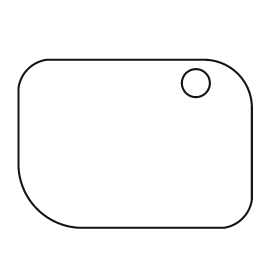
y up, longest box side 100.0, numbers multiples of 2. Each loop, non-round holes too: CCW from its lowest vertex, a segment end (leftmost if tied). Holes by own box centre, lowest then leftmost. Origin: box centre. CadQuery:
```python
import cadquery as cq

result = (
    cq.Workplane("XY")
    .moveTo(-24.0, -36.0)
    .lineTo(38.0, -36.0)
    .threePointArc((46.0, -32.0), (50.0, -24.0))
    .lineTo(50.0, 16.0)
    .threePointArc((44.0, 30.0), (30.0, 36.0))
    .lineTo(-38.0, 36.0)
    .threePointArc((-46.0, 32.0), (-50.0, 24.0))
    .lineTo(-50.0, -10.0)
    .threePointArc((-42.0, -28.0), (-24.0, -36.0))
    .close()
    .moveTo(26.0, 26.0)
    .circle(6.0)
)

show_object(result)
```